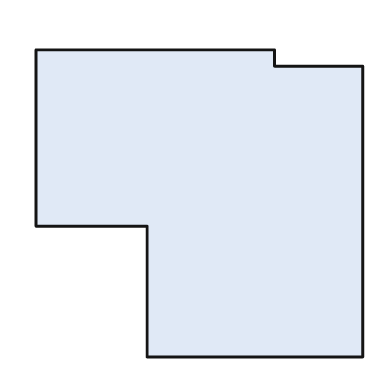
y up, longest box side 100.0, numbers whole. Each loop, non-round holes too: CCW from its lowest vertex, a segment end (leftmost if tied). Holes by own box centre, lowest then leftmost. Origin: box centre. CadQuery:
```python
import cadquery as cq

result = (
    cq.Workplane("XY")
    .moveTo(-16.0, -47.0)
    .lineTo(50.0, -47.0)
    .lineTo(50.0, 42.0)
    .lineTo(23.0, 42.0)
    .lineTo(23.0, 47.0)
    .lineTo(-50.0, 47.0)
    .lineTo(-50.0, -7.0)
    .lineTo(-16.0, -7.0)
    .close()
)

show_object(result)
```